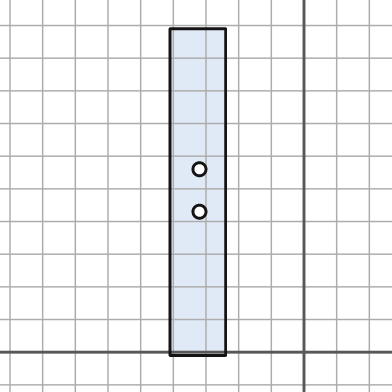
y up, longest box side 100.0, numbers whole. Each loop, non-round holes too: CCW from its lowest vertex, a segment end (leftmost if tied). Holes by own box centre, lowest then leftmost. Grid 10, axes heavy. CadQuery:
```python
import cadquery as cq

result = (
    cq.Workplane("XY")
    .moveTo(-41.0, -1.0)
    .lineTo(-24.0, -1.0)
    .lineTo(-24.0, 99.0)
    .lineTo(-41.0, 99.0)
    .close()
    .moveTo(-32.0, 43.0)
    .circle(2.0)
    .moveTo(-32.0, 56.0)
    .circle(2.0)
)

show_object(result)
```